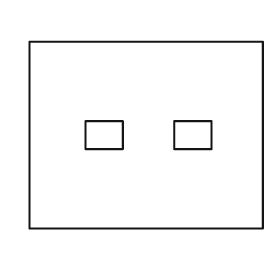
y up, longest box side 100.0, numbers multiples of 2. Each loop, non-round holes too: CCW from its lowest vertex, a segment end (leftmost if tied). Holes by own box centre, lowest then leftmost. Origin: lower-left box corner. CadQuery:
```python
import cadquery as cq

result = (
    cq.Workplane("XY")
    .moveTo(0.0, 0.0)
    .lineTo(100.0, 0.0)
    .lineTo(100.0, 80.0)
    .lineTo(0.0, 80.0)
    .close()
    .moveTo(24.0, 34.0)
    .lineTo(40.0, 34.0)
    .lineTo(40.0, 46.0)
    .lineTo(24.0, 46.0)
    .close()
    .moveTo(62.0, 34.0)
    .lineTo(78.0, 34.0)
    .lineTo(78.0, 46.0)
    .lineTo(62.0, 46.0)
    .close()
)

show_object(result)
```